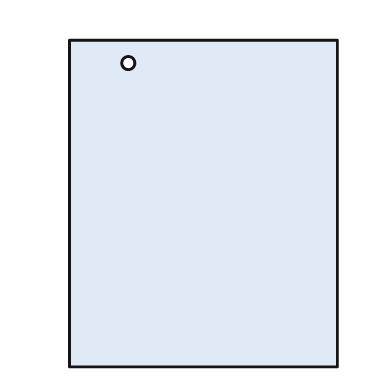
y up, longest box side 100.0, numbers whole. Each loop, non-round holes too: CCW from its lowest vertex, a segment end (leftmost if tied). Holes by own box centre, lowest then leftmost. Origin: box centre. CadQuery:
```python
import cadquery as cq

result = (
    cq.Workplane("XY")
    .moveTo(-41.0, -50.0)
    .lineTo(41.0, -50.0)
    .lineTo(41.0, 50.0)
    .lineTo(-41.0, 50.0)
    .close()
    .moveTo(-23.0, 43.0)
    .circle(2.0)
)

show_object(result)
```